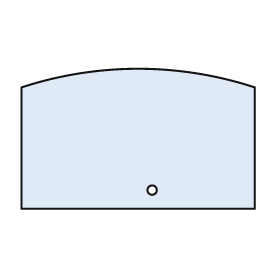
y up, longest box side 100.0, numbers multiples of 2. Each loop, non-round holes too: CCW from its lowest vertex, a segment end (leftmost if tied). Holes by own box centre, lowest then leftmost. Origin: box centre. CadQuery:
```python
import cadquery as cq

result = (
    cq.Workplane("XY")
    .moveTo(-50.0, -30.0)
    .lineTo(50.0, -30.0)
    .lineTo(50.0, 22.0)
    .threePointArc((0.0, 30.0), (-50.0, 22.0))
    .close()
    .moveTo(6.0, -22.0)
    .circle(2.0)
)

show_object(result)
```